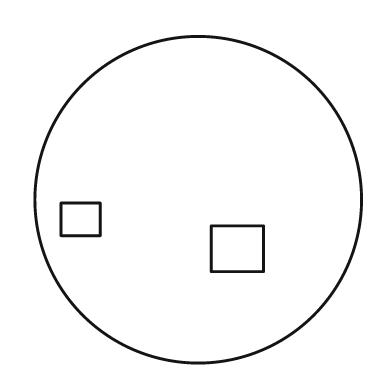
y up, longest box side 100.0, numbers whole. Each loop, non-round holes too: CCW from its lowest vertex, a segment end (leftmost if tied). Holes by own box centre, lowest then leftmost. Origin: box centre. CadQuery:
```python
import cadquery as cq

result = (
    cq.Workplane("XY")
    .moveTo(0.0, 0.0)
    .circle(50.0)
    .moveTo(4.0, -22.0)
    .lineTo(20.0, -22.0)
    .lineTo(20.0, -8.0)
    .lineTo(4.0, -8.0)
    .close()
    .moveTo(-42.0, -11.0)
    .lineTo(-30.0, -11.0)
    .lineTo(-30.0, -1.0)
    .lineTo(-42.0, -1.0)
    .close()
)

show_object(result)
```